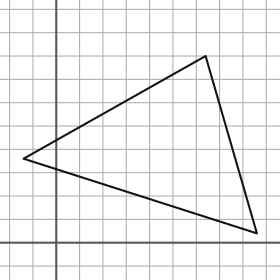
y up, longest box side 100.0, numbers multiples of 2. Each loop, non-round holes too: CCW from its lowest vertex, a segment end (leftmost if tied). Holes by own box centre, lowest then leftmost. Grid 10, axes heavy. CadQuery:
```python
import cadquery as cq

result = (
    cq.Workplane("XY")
    .moveTo(86.0, 4.0)
    .lineTo(64.0, 80.0)
    .lineTo(-14.0, 36.0)
    .close()
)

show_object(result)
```